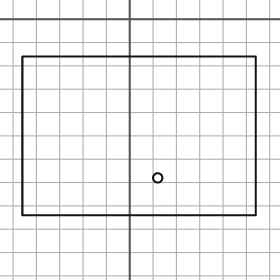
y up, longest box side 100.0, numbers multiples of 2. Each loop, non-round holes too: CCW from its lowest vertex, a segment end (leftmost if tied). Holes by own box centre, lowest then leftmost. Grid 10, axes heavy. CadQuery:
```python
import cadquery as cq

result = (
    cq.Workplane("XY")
    .moveTo(-46.0, -84.0)
    .lineTo(54.0, -84.0)
    .lineTo(54.0, -16.0)
    .lineTo(-46.0, -16.0)
    .close()
    .moveTo(12.0, -68.0)
    .circle(2.0)
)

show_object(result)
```